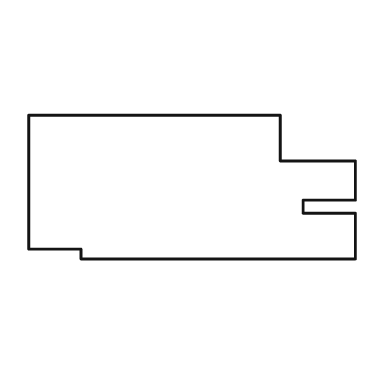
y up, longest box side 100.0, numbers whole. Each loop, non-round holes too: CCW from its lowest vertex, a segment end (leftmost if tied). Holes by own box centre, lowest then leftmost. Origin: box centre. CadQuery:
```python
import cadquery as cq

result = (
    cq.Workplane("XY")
    .moveTo(-34.0, -22.0)
    .lineTo(50.0, -22.0)
    .lineTo(50.0, -8.0)
    .lineTo(34.0, -8.0)
    .lineTo(34.0, -4.0)
    .lineTo(50.0, -4.0)
    .lineTo(50.0, 8.0)
    .lineTo(27.0, 8.0)
    .lineTo(27.0, 22.0)
    .lineTo(-50.0, 22.0)
    .lineTo(-50.0, -19.0)
    .lineTo(-34.0, -19.0)
    .close()
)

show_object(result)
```